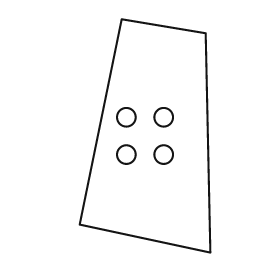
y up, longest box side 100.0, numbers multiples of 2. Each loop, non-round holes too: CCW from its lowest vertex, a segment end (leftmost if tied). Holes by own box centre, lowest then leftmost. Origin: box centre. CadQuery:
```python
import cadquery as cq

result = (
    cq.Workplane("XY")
    .moveTo(28.0, -50.0)
    .lineTo(26.0, 44.0)
    .lineTo(-10.0, 50.0)
    .lineTo(-28.0, -38.0)
    .close()
    .moveTo(-8.0, -8.0)
    .circle(4.0)
    .moveTo(8.0, -8.0)
    .circle(4.0)
    .moveTo(-8.0, 8.0)
    .circle(4.0)
    .moveTo(8.0, 8.0)
    .circle(4.0)
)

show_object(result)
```